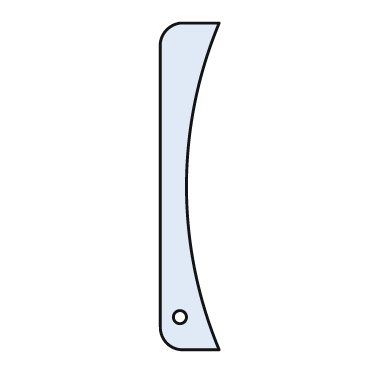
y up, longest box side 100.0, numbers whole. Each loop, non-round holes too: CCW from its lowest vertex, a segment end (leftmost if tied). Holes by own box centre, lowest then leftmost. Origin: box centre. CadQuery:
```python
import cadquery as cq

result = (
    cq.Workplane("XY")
    .moveTo(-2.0, -50.0)
    .lineTo(9.0, -50.0)
    .threePointArc((-1.0, 0.0), (9.0, 50.0))
    .lineTo(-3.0, 50.0)
    .threePointArc((-7.0, 48.0), (-9.0, 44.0))
    .lineTo(-9.0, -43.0)
    .threePointArc((-7.0, -48.0), (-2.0, -50.0))
    .close()
    .moveTo(-3.0, -40.0)
    .circle(2.0)
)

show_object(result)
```